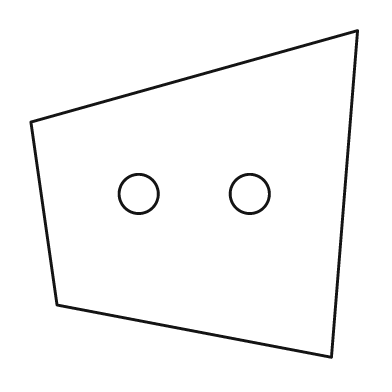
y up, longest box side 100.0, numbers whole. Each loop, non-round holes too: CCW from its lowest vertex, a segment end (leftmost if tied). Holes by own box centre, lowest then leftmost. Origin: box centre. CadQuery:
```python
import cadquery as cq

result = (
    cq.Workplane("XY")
    .moveTo(42.0, -50.0)
    .lineTo(50.0, 50.0)
    .lineTo(-50.0, 22.0)
    .lineTo(-42.0, -34.0)
    .close()
    .moveTo(-17.0, 0.0)
    .circle(6.0)
    .moveTo(17.0, 0.0)
    .circle(6.0)
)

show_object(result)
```